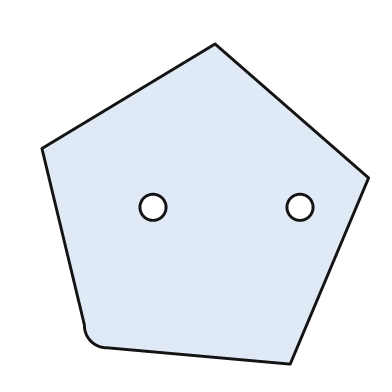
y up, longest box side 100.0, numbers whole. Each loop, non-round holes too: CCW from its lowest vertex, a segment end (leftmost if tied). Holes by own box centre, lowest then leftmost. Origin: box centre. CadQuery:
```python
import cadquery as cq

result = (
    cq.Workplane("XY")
    .moveTo(26.0, -49.0)
    .lineTo(50.0, 8.0)
    .lineTo(3.0, 49.0)
    .lineTo(-50.0, 17.0)
    .lineTo(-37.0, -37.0)
    .threePointArc((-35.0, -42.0), (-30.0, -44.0))
    .close()
    .moveTo(-16.0, -1.0)
    .circle(4.0)
    .moveTo(29.0, -1.0)
    .circle(4.0)
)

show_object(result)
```